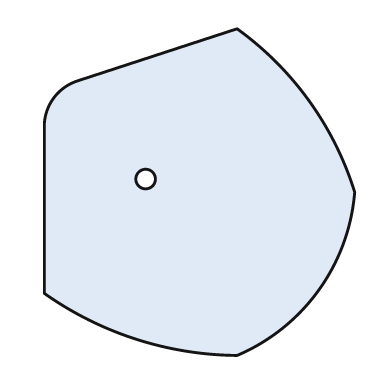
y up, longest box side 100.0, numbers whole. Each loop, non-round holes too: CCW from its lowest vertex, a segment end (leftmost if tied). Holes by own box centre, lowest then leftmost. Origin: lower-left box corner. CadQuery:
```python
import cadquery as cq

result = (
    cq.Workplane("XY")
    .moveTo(59.0, 0.0)
    .threePointArc((84.0, 20.0), (95.0, 50.0))
    .threePointArc((81.0, 78.0), (59.0, 100.0))
    .lineTo(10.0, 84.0)
    .threePointArc((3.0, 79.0), (0.0, 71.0))
    .lineTo(0.0, 19.0)
    .threePointArc((28.0, 5.0), (59.0, 0.0))
    .close()
    .moveTo(31.0, 54.0)
    .circle(3.0)
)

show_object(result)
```